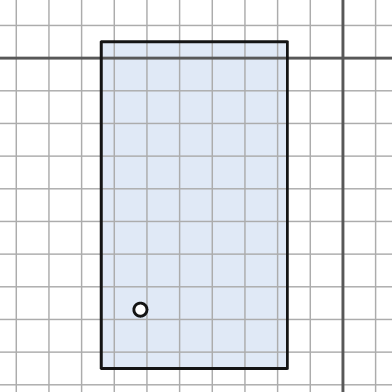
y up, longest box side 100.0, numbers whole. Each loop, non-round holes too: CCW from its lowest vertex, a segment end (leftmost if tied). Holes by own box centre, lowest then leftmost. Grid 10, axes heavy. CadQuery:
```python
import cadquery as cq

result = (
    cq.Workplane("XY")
    .moveTo(-74.0, -95.0)
    .lineTo(-17.0, -95.0)
    .lineTo(-17.0, 5.0)
    .lineTo(-74.0, 5.0)
    .close()
    .moveTo(-62.0, -77.0)
    .circle(2.0)
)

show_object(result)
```